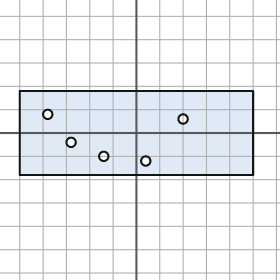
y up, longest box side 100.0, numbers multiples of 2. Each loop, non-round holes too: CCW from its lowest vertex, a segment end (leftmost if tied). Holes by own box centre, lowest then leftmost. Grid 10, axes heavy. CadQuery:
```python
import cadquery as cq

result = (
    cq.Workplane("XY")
    .moveTo(-50.0, -18.0)
    .lineTo(50.0, -18.0)
    .lineTo(50.0, 18.0)
    .lineTo(-50.0, 18.0)
    .close()
    .moveTo(4.0, -12.0)
    .circle(2.0)
    .moveTo(-14.0, -10.0)
    .circle(2.0)
    .moveTo(-28.0, -4.0)
    .circle(2.0)
    .moveTo(20.0, 6.0)
    .circle(2.0)
    .moveTo(-38.0, 8.0)
    .circle(2.0)
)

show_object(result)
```